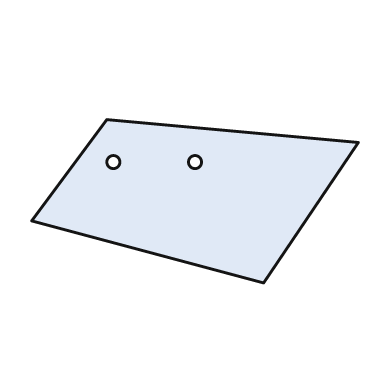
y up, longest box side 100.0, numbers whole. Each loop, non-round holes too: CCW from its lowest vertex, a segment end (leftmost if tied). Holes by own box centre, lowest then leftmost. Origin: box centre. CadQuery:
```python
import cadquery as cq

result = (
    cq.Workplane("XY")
    .moveTo(21.0, -25.0)
    .lineTo(50.0, 18.0)
    .lineTo(-27.0, 25.0)
    .lineTo(-50.0, -6.0)
    .close()
    .moveTo(-25.0, 12.0)
    .circle(2.0)
    .moveTo(0.0, 12.0)
    .circle(2.0)
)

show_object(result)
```